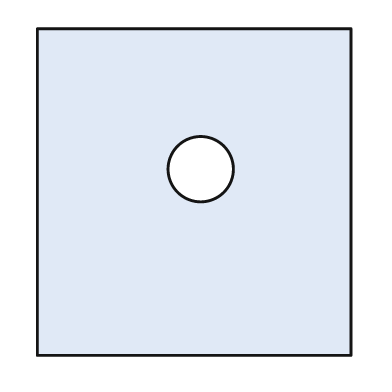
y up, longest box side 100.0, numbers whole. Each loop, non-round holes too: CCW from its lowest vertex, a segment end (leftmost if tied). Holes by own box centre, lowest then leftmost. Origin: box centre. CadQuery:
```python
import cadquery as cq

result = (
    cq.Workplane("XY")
    .moveTo(-48.0, -50.0)
    .lineTo(48.0, -50.0)
    .lineTo(48.0, 50.0)
    .lineTo(-48.0, 50.0)
    .close()
    .moveTo(2.0, 7.0)
    .circle(10.0)
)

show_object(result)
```